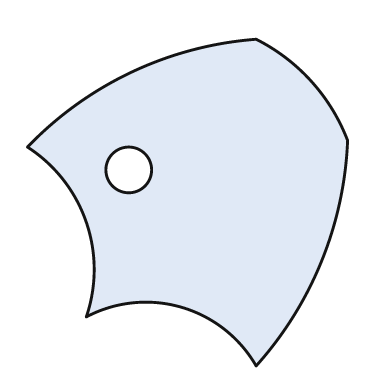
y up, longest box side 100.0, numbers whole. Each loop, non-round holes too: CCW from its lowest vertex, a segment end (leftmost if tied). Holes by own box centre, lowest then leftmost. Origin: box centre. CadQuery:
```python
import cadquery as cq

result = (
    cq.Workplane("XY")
    .moveTo(21.0, -50.0)
    .threePointArc((41.0, -18.0), (49.0, 19.0))
    .threePointArc((38.0, 37.0), (21.0, 50.0))
    .threePointArc((-17.0, 40.0), (-49.0, 17.0))
    .threePointArc((-31.0, -6.0), (-31.0, -35.0))
    .threePointArc((-2.0, -32.0), (21.0, -50.0))
    .close()
    .moveTo(-18.0, 10.0)
    .circle(7.0)
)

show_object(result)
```